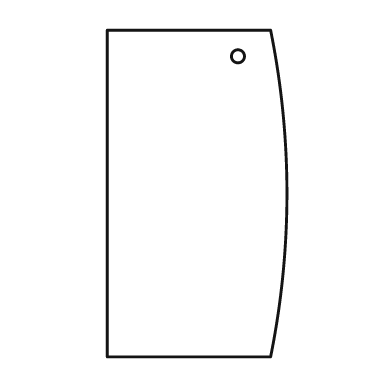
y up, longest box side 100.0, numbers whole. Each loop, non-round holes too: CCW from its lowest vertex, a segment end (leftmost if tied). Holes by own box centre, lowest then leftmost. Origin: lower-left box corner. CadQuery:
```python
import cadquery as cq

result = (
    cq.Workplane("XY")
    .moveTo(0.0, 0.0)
    .lineTo(50.0, 0.0)
    .threePointArc((55.0, 50.0), (50.0, 100.0))
    .lineTo(0.0, 100.0)
    .close()
    .moveTo(40.0, 92.0)
    .circle(2.0)
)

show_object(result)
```